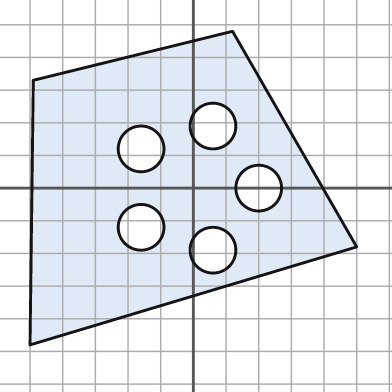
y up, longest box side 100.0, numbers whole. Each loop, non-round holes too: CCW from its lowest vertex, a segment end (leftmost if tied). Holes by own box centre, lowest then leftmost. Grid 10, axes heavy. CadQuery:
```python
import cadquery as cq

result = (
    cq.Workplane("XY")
    .moveTo(-50.0, -48.0)
    .lineTo(50.0, -18.0)
    .lineTo(12.0, 48.0)
    .lineTo(-49.0, 33.0)
    .close()
    .moveTo(6.0, -19.0)
    .circle(7.0)
    .moveTo(-16.0, -12.0)
    .circle(7.0)
    .moveTo(20.0, 0.0)
    .circle(7.0)
    .moveTo(-16.0, 12.0)
    .circle(7.0)
    .moveTo(6.0, 19.0)
    .circle(7.0)
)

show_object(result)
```